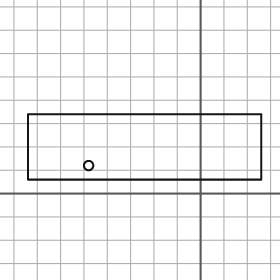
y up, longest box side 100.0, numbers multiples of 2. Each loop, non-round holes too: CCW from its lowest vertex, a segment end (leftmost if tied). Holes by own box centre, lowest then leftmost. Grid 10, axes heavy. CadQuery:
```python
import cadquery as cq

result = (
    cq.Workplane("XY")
    .moveTo(-74.0, 6.0)
    .lineTo(26.0, 6.0)
    .lineTo(26.0, 34.0)
    .lineTo(-74.0, 34.0)
    .close()
    .moveTo(-48.0, 12.0)
    .circle(2.0)
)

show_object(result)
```